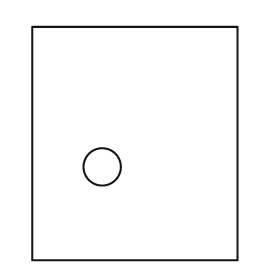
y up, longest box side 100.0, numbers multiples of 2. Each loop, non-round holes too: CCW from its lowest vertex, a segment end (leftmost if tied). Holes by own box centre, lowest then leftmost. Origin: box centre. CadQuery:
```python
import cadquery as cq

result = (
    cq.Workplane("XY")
    .moveTo(-44.0, -50.0)
    .lineTo(44.0, -50.0)
    .lineTo(44.0, 50.0)
    .lineTo(-44.0, 50.0)
    .close()
    .moveTo(-14.0, -10.0)
    .circle(8.0)
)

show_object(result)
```